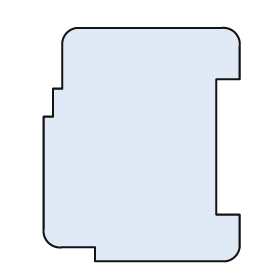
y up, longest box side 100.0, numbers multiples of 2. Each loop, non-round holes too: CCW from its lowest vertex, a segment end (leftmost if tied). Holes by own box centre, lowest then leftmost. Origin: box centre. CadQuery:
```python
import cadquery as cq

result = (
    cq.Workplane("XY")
    .moveTo(-20.0, -50.0)
    .lineTo(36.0, -50.0)
    .threePointArc((40.0, -48.0), (42.0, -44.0))
    .lineTo(42.0, -30.0)
    .lineTo(32.0, -30.0)
    .lineTo(32.0, 28.0)
    .lineTo(42.0, 28.0)
    .lineTo(42.0, 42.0)
    .threePointArc((40.0, 48.0), (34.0, 50.0))
    .lineTo(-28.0, 50.0)
    .threePointArc((-32.0, 48.0), (-34.0, 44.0))
    .lineTo(-34.0, 24.0)
    .lineTo(-38.0, 24.0)
    .lineTo(-38.0, 12.0)
    .lineTo(-42.0, 12.0)
    .lineTo(-42.0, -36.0)
    .threePointArc((-40.0, -42.0), (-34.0, -44.0))
    .lineTo(-20.0, -44.0)
    .close()
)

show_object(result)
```